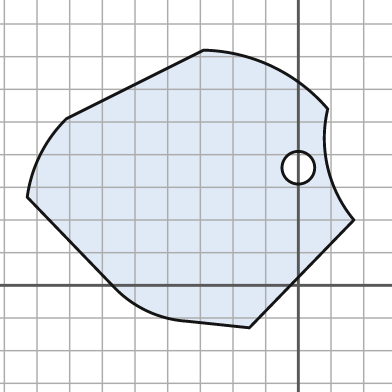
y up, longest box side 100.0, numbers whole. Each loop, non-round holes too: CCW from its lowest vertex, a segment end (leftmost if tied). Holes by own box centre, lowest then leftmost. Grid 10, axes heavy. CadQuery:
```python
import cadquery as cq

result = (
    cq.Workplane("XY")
    .moveTo(-15.0, -13.0)
    .lineTo(17.0, 20.0)
    .threePointArc((9.0, 36.0), (9.0, 54.0))
    .threePointArc((-8.0, 67.0), (-29.0, 72.0))
    .lineTo(-71.0, 51.0)
    .threePointArc((-79.0, 40.0), (-83.0, 27.0))
    .lineTo(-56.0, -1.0)
    .threePointArc((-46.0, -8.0), (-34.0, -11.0))
    .close()
    .moveTo(0.0, 36.0)
    .circle(5.0)
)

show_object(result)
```